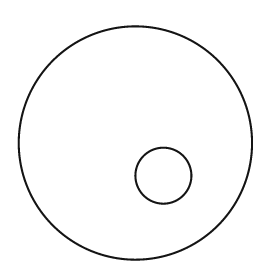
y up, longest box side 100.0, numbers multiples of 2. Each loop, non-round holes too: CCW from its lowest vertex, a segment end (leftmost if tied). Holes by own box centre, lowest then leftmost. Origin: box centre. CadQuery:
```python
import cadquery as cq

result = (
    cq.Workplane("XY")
    .moveTo(0.0, 0.0)
    .circle(50.0)
    .moveTo(12.0, -14.0)
    .circle(12.0)
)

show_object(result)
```